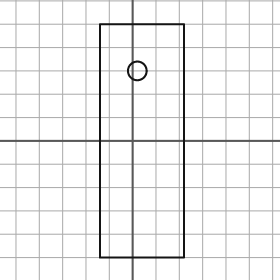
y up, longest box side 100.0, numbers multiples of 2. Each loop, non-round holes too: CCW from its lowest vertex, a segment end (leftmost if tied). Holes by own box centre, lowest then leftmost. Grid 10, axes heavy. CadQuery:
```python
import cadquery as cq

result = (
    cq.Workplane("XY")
    .moveTo(-14.0, -50.0)
    .lineTo(22.0, -50.0)
    .lineTo(22.0, 50.0)
    .lineTo(-14.0, 50.0)
    .close()
    .moveTo(2.0, 30.0)
    .circle(4.0)
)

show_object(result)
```